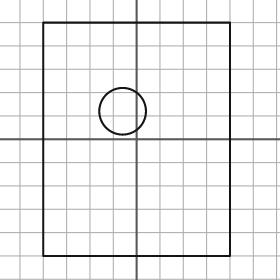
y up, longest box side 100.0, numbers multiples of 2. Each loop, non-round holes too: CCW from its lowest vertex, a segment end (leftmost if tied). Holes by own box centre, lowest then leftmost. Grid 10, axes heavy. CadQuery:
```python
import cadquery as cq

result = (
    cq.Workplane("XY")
    .moveTo(-40.0, -50.0)
    .lineTo(40.0, -50.0)
    .lineTo(40.0, 50.0)
    .lineTo(-40.0, 50.0)
    .close()
    .moveTo(-6.0, 12.0)
    .circle(10.0)
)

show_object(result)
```